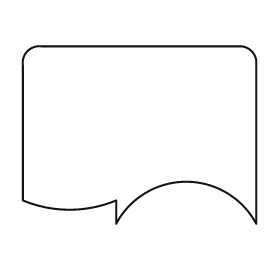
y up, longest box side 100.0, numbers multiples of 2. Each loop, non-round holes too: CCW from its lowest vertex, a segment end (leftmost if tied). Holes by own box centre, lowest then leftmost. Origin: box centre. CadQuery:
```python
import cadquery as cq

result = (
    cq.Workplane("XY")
    .moveTo(-10.0, -38.0)
    .threePointArc((20.0, -20.0), (50.0, -38.0))
    .lineTo(50.0, 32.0)
    .threePointArc((48.0, 36.0), (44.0, 38.0))
    .lineTo(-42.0, 38.0)
    .threePointArc((-48.0, 36.0), (-50.0, 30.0))
    .lineTo(-50.0, -28.0)
    .threePointArc((-30.0, -32.0), (-10.0, -28.0))
    .close()
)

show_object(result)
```